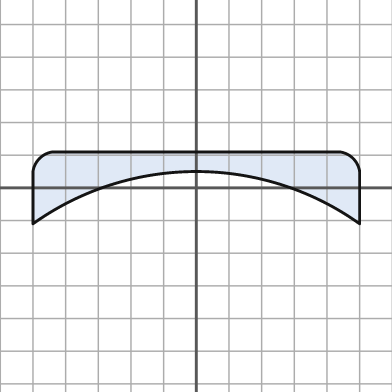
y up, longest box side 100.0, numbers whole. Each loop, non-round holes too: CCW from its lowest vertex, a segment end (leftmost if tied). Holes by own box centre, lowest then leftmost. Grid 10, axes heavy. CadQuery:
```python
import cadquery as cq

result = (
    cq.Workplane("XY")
    .moveTo(-50.0, -11.0)
    .threePointArc((0.0, 5.0), (50.0, -11.0))
    .lineTo(50.0, 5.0)
    .threePointArc((48.0, 9.0), (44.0, 11.0))
    .lineTo(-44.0, 11.0)
    .threePointArc((-48.0, 9.0), (-50.0, 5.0))
    .close()
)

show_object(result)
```